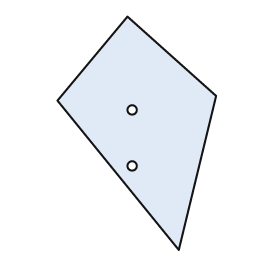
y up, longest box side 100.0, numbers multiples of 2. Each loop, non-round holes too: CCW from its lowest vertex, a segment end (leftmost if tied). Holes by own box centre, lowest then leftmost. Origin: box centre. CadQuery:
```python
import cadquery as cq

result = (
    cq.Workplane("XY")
    .moveTo(18.0, -50.0)
    .lineTo(34.0, 16.0)
    .lineTo(-4.0, 50.0)
    .lineTo(-34.0, 14.0)
    .close()
    .moveTo(-2.0, -14.0)
    .circle(2.0)
    .moveTo(-2.0, 10.0)
    .circle(2.0)
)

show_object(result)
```